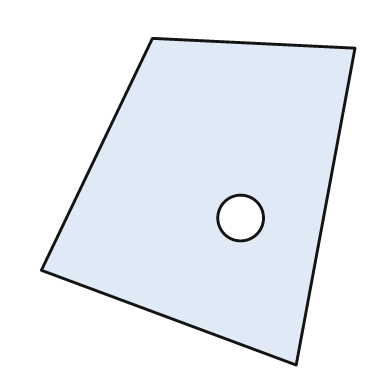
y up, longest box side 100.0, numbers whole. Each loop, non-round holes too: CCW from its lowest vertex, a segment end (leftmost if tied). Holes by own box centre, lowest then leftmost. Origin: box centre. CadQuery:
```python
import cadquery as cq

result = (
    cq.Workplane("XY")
    .moveTo(30.0, -50.0)
    .lineTo(48.0, 47.0)
    .lineTo(-14.0, 50.0)
    .lineTo(-48.0, -21.0)
    .close()
    .moveTo(13.0, -5.0)
    .circle(7.0)
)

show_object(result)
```